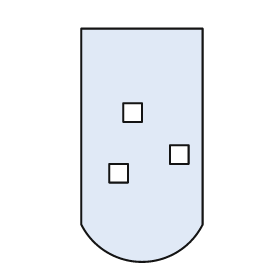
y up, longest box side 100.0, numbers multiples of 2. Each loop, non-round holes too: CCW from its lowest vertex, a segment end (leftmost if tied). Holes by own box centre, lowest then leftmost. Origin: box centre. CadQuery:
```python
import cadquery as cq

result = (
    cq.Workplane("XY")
    .moveTo(-26.0, -34.0)
    .threePointArc((0.0, -50.0), (26.0, -34.0))
    .lineTo(26.0, 50.0)
    .lineTo(-26.0, 50.0)
    .close()
    .moveTo(-14.0, -16.0)
    .lineTo(-6.0, -16.0)
    .lineTo(-6.0, -8.0)
    .lineTo(-14.0, -8.0)
    .close()
    .moveTo(12.0, -8.0)
    .lineTo(20.0, -8.0)
    .lineTo(20.0, 0.0)
    .lineTo(12.0, 0.0)
    .close()
    .moveTo(-8.0, 10.0)
    .lineTo(0.0, 10.0)
    .lineTo(0.0, 18.0)
    .lineTo(-8.0, 18.0)
    .close()
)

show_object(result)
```